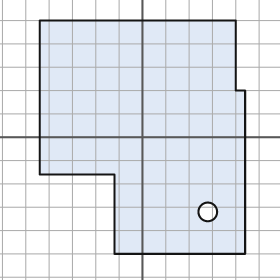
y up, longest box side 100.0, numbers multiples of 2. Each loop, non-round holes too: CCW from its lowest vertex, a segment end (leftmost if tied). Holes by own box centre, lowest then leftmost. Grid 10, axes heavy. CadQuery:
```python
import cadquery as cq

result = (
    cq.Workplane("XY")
    .moveTo(-12.0, -50.0)
    .lineTo(44.0, -50.0)
    .lineTo(44.0, 20.0)
    .lineTo(40.0, 20.0)
    .lineTo(40.0, 50.0)
    .lineTo(-44.0, 50.0)
    .lineTo(-44.0, -16.0)
    .lineTo(-12.0, -16.0)
    .close()
    .moveTo(28.0, -32.0)
    .circle(4.0)
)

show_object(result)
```